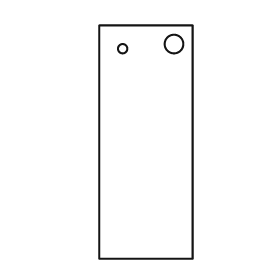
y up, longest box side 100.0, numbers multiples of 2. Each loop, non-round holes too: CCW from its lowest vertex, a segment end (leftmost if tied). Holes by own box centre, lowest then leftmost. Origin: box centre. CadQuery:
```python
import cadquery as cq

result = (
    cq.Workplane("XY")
    .moveTo(-20.0, -50.0)
    .lineTo(20.0, -50.0)
    .lineTo(20.0, 50.0)
    .lineTo(-20.0, 50.0)
    .close()
    .moveTo(-10.0, 40.0)
    .circle(2.0)
    .moveTo(12.0, 42.0)
    .circle(4.0)
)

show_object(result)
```